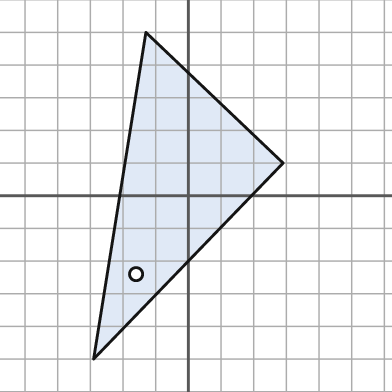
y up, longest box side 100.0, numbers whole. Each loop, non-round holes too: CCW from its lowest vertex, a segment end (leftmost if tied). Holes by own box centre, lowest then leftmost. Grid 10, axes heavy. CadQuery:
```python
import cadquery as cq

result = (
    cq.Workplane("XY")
    .moveTo(-29.0, -50.0)
    .lineTo(29.0, 10.0)
    .lineTo(-13.0, 50.0)
    .close()
    .moveTo(-16.0, -24.0)
    .circle(2.0)
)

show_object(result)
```